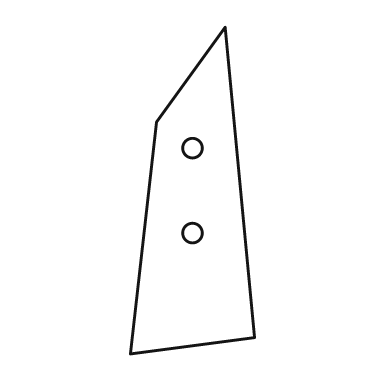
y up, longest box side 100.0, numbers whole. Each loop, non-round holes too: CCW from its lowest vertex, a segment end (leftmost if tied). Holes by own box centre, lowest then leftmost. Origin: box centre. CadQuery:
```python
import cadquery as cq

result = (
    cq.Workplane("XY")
    .moveTo(-19.0, -50.0)
    .lineTo(19.0, -45.0)
    .lineTo(10.0, 50.0)
    .lineTo(-11.0, 21.0)
    .close()
    .moveTo(0.0, -13.0)
    .circle(3.0)
    .moveTo(0.0, 13.0)
    .circle(3.0)
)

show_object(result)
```